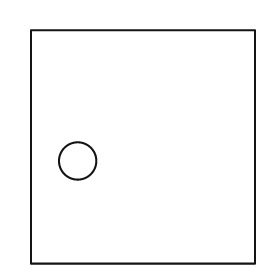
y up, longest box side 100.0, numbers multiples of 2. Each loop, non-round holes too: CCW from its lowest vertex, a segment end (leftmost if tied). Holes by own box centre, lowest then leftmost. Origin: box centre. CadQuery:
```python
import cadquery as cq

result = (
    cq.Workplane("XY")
    .moveTo(-48.0, -50.0)
    .lineTo(48.0, -50.0)
    .lineTo(48.0, 50.0)
    .lineTo(-48.0, 50.0)
    .close()
    .moveTo(-28.0, -6.0)
    .circle(8.0)
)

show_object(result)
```